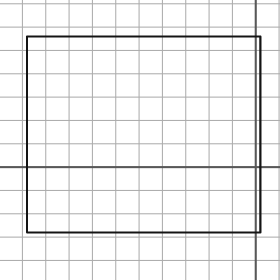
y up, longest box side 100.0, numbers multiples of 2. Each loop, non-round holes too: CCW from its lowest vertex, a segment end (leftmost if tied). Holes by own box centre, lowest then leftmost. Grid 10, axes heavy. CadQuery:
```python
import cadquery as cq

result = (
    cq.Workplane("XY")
    .moveTo(-98.0, -28.0)
    .lineTo(2.0, -28.0)
    .lineTo(2.0, 56.0)
    .lineTo(-98.0, 56.0)
    .close()
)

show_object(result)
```